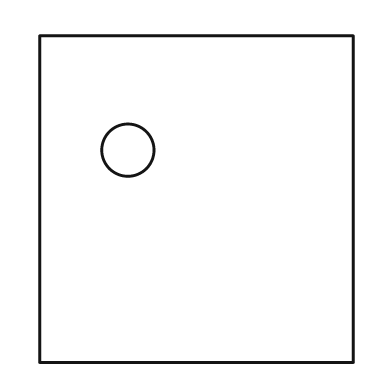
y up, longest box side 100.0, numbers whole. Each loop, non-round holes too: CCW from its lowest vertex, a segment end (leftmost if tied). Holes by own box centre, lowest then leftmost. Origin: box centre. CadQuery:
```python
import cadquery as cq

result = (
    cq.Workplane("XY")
    .moveTo(-48.0, -50.0)
    .lineTo(48.0, -50.0)
    .lineTo(48.0, 50.0)
    .lineTo(-48.0, 50.0)
    .close()
    .moveTo(-21.0, 15.0)
    .circle(8.0)
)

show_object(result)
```